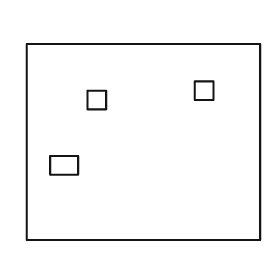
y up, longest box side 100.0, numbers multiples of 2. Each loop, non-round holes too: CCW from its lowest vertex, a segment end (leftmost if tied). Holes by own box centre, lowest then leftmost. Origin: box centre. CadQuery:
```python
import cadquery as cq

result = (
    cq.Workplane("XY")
    .moveTo(-50.0, -42.0)
    .lineTo(50.0, -42.0)
    .lineTo(50.0, 42.0)
    .lineTo(-50.0, 42.0)
    .close()
    .moveTo(-40.0, -14.0)
    .lineTo(-28.0, -14.0)
    .lineTo(-28.0, -6.0)
    .lineTo(-40.0, -6.0)
    .close()
    .moveTo(-24.0, 14.0)
    .lineTo(-16.0, 14.0)
    .lineTo(-16.0, 22.0)
    .lineTo(-24.0, 22.0)
    .close()
    .moveTo(22.0, 18.0)
    .lineTo(30.0, 18.0)
    .lineTo(30.0, 26.0)
    .lineTo(22.0, 26.0)
    .close()
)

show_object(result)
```